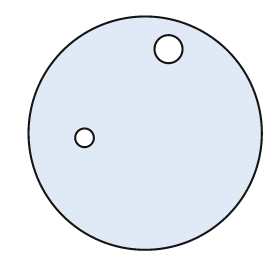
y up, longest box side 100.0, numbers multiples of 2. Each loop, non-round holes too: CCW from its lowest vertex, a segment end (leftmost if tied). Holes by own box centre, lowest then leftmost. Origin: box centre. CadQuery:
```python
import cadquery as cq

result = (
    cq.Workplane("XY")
    .moveTo(0.0, 0.0)
    .circle(50.0)
    .moveTo(-26.0, -2.0)
    .circle(4.0)
    .moveTo(10.0, 36.0)
    .circle(6.0)
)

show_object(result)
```